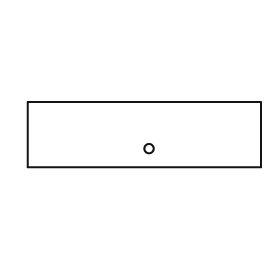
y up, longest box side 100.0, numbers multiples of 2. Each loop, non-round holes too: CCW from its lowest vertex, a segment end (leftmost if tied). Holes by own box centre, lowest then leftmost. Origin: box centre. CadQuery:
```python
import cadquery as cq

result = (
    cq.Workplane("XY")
    .moveTo(-50.0, -14.0)
    .lineTo(50.0, -14.0)
    .lineTo(50.0, 14.0)
    .lineTo(-50.0, 14.0)
    .close()
    .moveTo(2.0, -6.0)
    .circle(2.0)
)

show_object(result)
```